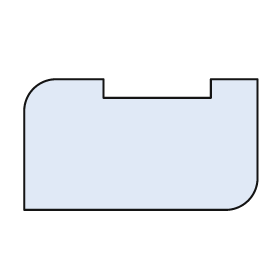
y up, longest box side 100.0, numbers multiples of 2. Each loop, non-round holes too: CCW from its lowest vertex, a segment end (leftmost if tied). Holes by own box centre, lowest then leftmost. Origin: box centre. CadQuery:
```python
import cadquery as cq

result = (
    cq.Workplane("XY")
    .moveTo(-50.0, -28.0)
    .lineTo(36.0, -28.0)
    .threePointArc((46.0, -24.0), (50.0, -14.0))
    .lineTo(50.0, 28.0)
    .lineTo(30.0, 28.0)
    .lineTo(30.0, 20.0)
    .lineTo(-16.0, 20.0)
    .lineTo(-16.0, 28.0)
    .lineTo(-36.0, 28.0)
    .threePointArc((-46.0, 24.0), (-50.0, 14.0))
    .close()
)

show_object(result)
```